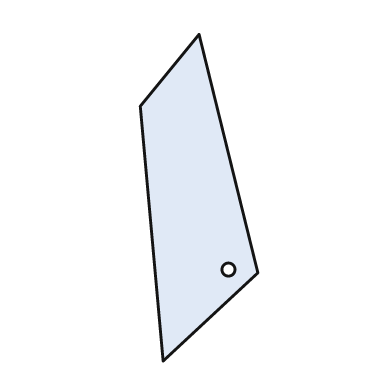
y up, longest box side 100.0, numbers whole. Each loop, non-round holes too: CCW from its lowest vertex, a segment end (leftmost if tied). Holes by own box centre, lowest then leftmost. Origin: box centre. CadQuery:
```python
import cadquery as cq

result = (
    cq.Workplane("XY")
    .moveTo(-11.0, -50.0)
    .lineTo(18.0, -23.0)
    .lineTo(0.0, 50.0)
    .lineTo(-18.0, 28.0)
    .close()
    .moveTo(9.0, -22.0)
    .circle(2.0)
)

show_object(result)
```